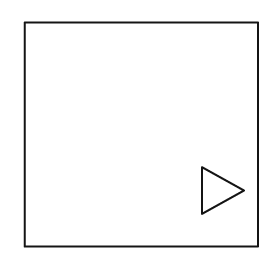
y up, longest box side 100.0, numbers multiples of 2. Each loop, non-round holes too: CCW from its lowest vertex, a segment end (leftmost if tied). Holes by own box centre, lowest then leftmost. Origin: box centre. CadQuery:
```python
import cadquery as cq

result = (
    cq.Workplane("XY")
    .moveTo(-50.0, -48.0)
    .lineTo(50.0, -48.0)
    .lineTo(50.0, 48.0)
    .lineTo(-50.0, 48.0)
    .close()
    .moveTo(26.0, -34.0)
    .lineTo(44.0, -24.0)
    .lineTo(26.0, -14.0)
    .close()
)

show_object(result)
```